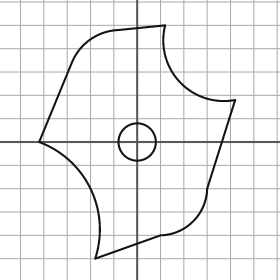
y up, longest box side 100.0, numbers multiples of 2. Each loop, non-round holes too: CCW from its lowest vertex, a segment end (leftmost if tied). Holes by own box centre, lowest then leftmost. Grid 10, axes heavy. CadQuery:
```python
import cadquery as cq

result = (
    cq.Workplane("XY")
    .moveTo(-18.0, -50.0)
    .lineTo(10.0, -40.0)
    .threePointArc((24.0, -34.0), (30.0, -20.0))
    .lineTo(42.0, 18.0)
    .threePointArc((18.0, 26.0), (12.0, 50.0))
    .lineTo(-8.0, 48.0)
    .threePointArc((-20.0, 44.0), (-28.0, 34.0))
    .lineTo(-42.0, 0.0)
    .threePointArc((-20.0, -20.0), (-18.0, -50.0))
    .close()
    .moveTo(0.0, 0.0)
    .circle(8.0)
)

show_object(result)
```